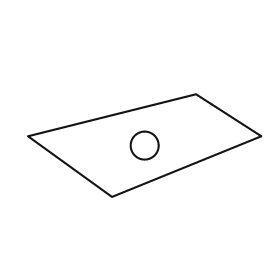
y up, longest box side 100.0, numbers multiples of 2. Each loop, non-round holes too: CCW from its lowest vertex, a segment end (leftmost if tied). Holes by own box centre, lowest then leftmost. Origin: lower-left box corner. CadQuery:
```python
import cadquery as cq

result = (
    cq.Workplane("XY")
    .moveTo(36.0, 0.0)
    .lineTo(100.0, 26.0)
    .lineTo(72.0, 44.0)
    .lineTo(0.0, 26.0)
    .close()
    .moveTo(50.0, 22.0)
    .circle(6.0)
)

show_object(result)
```